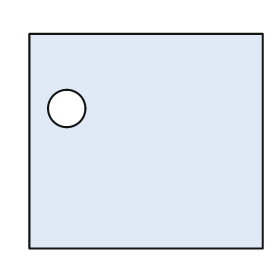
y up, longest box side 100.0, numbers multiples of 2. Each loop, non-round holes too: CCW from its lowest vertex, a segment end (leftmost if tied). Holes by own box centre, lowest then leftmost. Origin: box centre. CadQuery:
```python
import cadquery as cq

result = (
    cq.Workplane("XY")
    .moveTo(-50.0, -46.0)
    .lineTo(50.0, -46.0)
    .lineTo(50.0, 46.0)
    .lineTo(-50.0, 46.0)
    .close()
    .moveTo(-34.0, 14.0)
    .circle(8.0)
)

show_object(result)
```